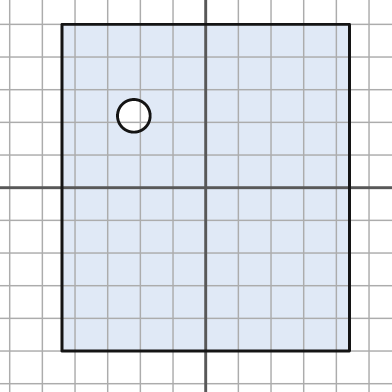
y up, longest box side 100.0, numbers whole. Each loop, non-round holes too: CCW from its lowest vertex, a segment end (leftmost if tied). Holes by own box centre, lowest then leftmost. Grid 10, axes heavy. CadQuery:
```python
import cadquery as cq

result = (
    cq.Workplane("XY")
    .moveTo(-44.0, -50.0)
    .lineTo(44.0, -50.0)
    .lineTo(44.0, 50.0)
    .lineTo(-44.0, 50.0)
    .close()
    .moveTo(-22.0, 22.0)
    .circle(5.0)
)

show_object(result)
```